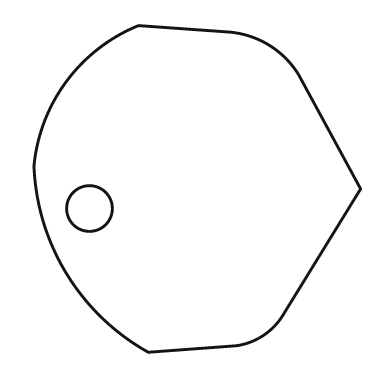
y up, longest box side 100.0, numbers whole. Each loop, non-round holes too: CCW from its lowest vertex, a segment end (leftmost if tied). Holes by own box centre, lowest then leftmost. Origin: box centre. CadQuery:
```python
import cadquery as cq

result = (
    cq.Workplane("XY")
    .moveTo(-15.0, -50.0)
    .lineTo(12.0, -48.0)
    .threePointArc((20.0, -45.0), (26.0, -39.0))
    .lineTo(50.0, 0.0)
    .lineTo(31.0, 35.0)
    .threePointArc((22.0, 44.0), (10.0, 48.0))
    .lineTo(-18.0, 50.0)
    .threePointArc((-40.0, 33.0), (-50.0, 7.0))
    .threePointArc((-40.0, -26.0), (-15.0, -50.0))
    .close()
    .moveTo(-33.0, -6.0)
    .circle(7.0)
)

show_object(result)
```